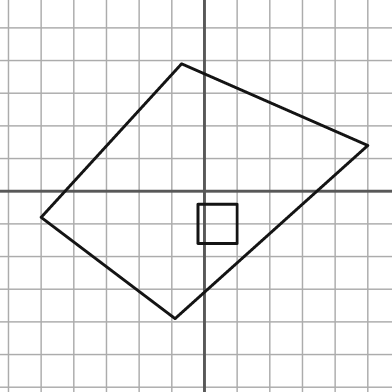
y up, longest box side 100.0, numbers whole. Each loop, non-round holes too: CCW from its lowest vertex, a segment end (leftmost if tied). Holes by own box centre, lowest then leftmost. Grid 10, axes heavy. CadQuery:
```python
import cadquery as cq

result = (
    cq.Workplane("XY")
    .moveTo(-9.0, -39.0)
    .lineTo(50.0, 14.0)
    .lineTo(-7.0, 39.0)
    .lineTo(-50.0, -8.0)
    .close()
    .moveTo(-2.0, -16.0)
    .lineTo(10.0, -16.0)
    .lineTo(10.0, -4.0)
    .lineTo(-2.0, -4.0)
    .close()
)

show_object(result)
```